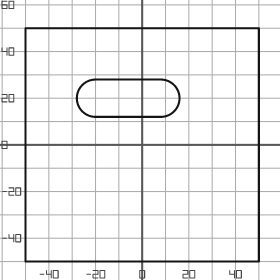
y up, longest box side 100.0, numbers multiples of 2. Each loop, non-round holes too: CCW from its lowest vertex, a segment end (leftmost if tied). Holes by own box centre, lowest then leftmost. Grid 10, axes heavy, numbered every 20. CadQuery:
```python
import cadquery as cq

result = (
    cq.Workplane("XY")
    .moveTo(-50.0, -50.0)
    .lineTo(50.0, -50.0)
    .lineTo(50.0, 50.0)
    .lineTo(-50.0, 50.0)
    .close()
    .moveTo(-20.0, 12.0)
    .lineTo(8.0, 12.0)
    .threePointArc((16.0, 20.0), (8.0, 28.0))
    .lineTo(-20.0, 28.0)
    .threePointArc((-28.0, 20.0), (-20.0, 12.0))
    .close()
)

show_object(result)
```